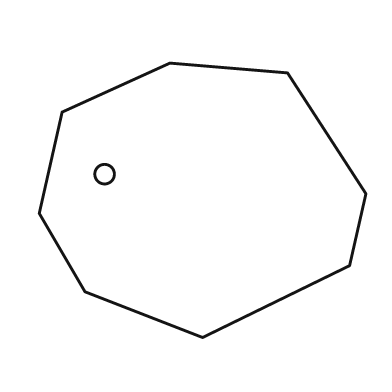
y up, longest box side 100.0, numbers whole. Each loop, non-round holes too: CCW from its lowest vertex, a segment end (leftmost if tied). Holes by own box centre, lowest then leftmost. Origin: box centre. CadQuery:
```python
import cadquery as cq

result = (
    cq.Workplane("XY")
    .moveTo(0.0, -42.0)
    .lineTo(45.0, -20.0)
    .lineTo(50.0, 2.0)
    .lineTo(26.0, 39.0)
    .lineTo(-10.0, 42.0)
    .lineTo(-43.0, 27.0)
    .lineTo(-50.0, -4.0)
    .lineTo(-36.0, -28.0)
    .close()
    .moveTo(-30.0, 8.0)
    .circle(3.0)
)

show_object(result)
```